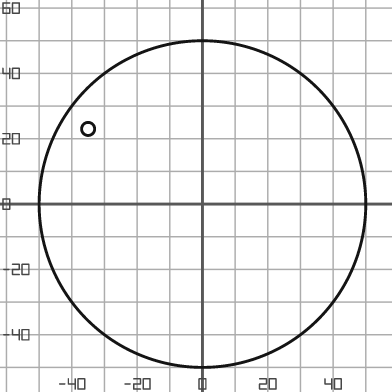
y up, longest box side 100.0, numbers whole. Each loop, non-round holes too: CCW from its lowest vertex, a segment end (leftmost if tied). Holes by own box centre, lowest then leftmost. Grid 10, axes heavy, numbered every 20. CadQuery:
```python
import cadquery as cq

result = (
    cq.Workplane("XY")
    .moveTo(0.0, 0.0)
    .circle(50.0)
    .moveTo(-35.0, 23.0)
    .circle(2.0)
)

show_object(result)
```